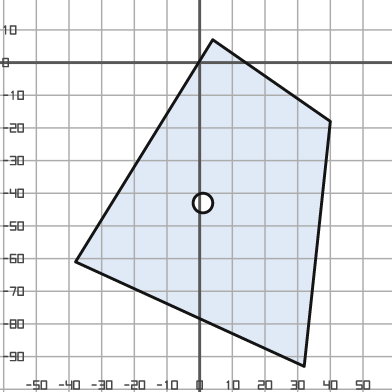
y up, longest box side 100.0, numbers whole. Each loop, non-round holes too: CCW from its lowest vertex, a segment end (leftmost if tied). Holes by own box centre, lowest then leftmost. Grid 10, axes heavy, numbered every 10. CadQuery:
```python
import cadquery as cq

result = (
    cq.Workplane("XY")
    .moveTo(32.0, -93.0)
    .lineTo(40.0, -18.0)
    .lineTo(4.0, 7.0)
    .lineTo(-38.0, -61.0)
    .close()
    .moveTo(1.0, -43.0)
    .circle(3.0)
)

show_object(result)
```